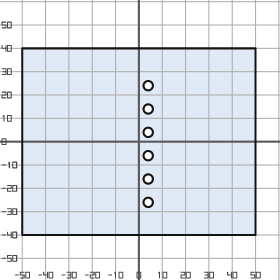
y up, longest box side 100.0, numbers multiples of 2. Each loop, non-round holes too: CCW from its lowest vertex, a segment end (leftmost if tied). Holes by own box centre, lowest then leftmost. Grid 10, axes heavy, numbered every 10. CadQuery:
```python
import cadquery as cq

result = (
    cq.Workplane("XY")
    .moveTo(-50.0, -40.0)
    .lineTo(50.0, -40.0)
    .lineTo(50.0, 40.0)
    .lineTo(-50.0, 40.0)
    .close()
    .moveTo(4.0, -26.0)
    .circle(2.0)
    .moveTo(4.0, -16.0)
    .circle(2.0)
    .moveTo(4.0, -6.0)
    .circle(2.0)
    .moveTo(4.0, 4.0)
    .circle(2.0)
    .moveTo(4.0, 14.0)
    .circle(2.0)
    .moveTo(4.0, 24.0)
    .circle(2.0)
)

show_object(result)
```